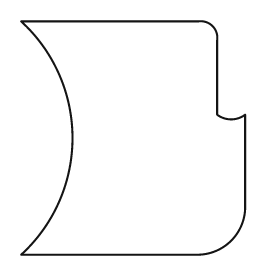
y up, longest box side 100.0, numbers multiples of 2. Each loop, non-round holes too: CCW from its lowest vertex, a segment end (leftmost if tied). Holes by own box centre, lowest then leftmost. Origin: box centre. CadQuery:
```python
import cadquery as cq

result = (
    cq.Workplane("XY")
    .moveTo(-48.0, -50.0)
    .lineTo(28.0, -50.0)
    .threePointArc((42.0, -44.0), (48.0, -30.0))
    .lineTo(48.0, 10.0)
    .threePointArc((42.0, 8.0), (36.0, 10.0))
    .lineTo(36.0, 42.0)
    .threePointArc((34.0, 48.0), (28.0, 50.0))
    .lineTo(-48.0, 50.0)
    .threePointArc((-26.0, 0.0), (-48.0, -50.0))
    .close()
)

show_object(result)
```